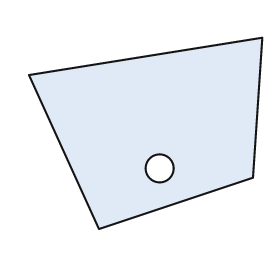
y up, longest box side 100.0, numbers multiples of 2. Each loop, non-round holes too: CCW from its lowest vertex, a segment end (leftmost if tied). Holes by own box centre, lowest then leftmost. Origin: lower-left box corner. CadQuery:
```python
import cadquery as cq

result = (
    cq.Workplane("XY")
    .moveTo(30.0, 0.0)
    .lineTo(96.0, 22.0)
    .lineTo(100.0, 82.0)
    .lineTo(0.0, 66.0)
    .close()
    .moveTo(56.0, 26.0)
    .circle(6.0)
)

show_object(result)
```